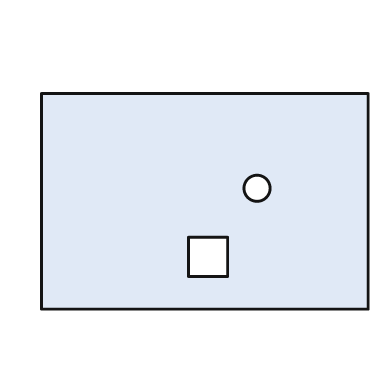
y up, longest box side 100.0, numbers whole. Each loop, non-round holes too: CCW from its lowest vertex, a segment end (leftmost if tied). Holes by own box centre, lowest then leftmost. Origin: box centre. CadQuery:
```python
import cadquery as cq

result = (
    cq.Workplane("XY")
    .moveTo(-50.0, -33.0)
    .lineTo(50.0, -33.0)
    .lineTo(50.0, 33.0)
    .lineTo(-50.0, 33.0)
    .close()
    .moveTo(-5.0, -23.0)
    .lineTo(7.0, -23.0)
    .lineTo(7.0, -11.0)
    .lineTo(-5.0, -11.0)
    .close()
    .moveTo(16.0, 4.0)
    .circle(4.0)
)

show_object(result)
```